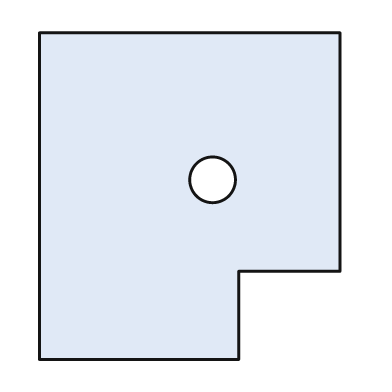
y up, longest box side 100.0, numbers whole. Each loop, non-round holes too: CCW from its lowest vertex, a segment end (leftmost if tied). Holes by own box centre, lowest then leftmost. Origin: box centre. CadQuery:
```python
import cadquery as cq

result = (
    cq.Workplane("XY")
    .moveTo(-46.0, -50.0)
    .lineTo(15.0, -50.0)
    .lineTo(15.0, -23.0)
    .lineTo(46.0, -23.0)
    .lineTo(46.0, 50.0)
    .lineTo(-46.0, 50.0)
    .close()
    .moveTo(7.0, 5.0)
    .circle(7.0)
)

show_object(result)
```